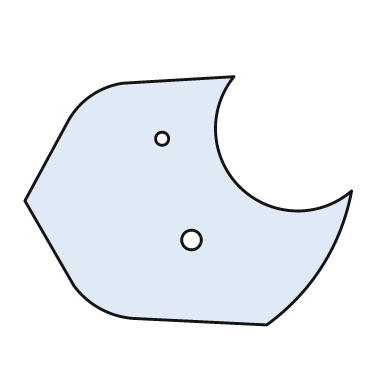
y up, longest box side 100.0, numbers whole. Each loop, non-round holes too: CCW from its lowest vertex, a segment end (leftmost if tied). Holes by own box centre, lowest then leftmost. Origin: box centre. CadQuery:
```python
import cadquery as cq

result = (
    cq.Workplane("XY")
    .moveTo(24.0, -38.0)
    .threePointArc((41.0, -20.0), (50.0, 3.0))
    .threePointArc((16.0, 4.0), (14.0, 38.0))
    .lineTo(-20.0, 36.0)
    .threePointArc((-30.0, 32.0), (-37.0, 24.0))
    .lineTo(-50.0, 0.0)
    .lineTo(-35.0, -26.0)
    .threePointArc((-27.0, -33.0), (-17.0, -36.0))
    .close()
    .moveTo(1.0, -12.0)
    .circle(3.0)
    .moveTo(-8.0, 19.0)
    .circle(2.0)
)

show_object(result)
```